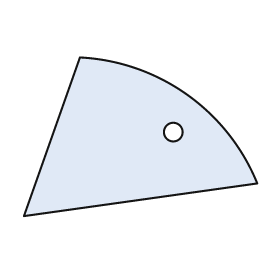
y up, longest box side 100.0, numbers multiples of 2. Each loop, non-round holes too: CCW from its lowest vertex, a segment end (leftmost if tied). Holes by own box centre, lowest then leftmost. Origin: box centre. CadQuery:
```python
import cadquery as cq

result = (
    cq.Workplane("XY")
    .moveTo(-50.0, -34.0)
    .lineTo(50.0, -20.0)
    .threePointArc((20.0, 18.0), (-26.0, 34.0))
    .close()
    .moveTo(14.0, 2.0)
    .circle(4.0)
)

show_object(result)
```